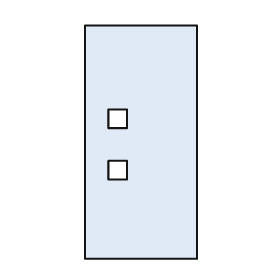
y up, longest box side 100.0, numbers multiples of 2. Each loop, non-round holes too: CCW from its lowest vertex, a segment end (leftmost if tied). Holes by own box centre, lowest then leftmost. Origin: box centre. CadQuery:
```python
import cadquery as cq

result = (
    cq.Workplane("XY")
    .moveTo(-24.0, -50.0)
    .lineTo(24.0, -50.0)
    .lineTo(24.0, 50.0)
    .lineTo(-24.0, 50.0)
    .close()
    .moveTo(-14.0, -16.0)
    .lineTo(-6.0, -16.0)
    .lineTo(-6.0, -8.0)
    .lineTo(-14.0, -8.0)
    .close()
    .moveTo(-14.0, 6.0)
    .lineTo(-6.0, 6.0)
    .lineTo(-6.0, 14.0)
    .lineTo(-14.0, 14.0)
    .close()
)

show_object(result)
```